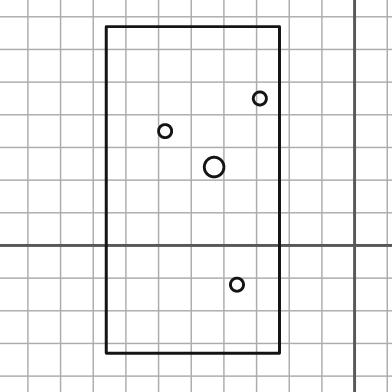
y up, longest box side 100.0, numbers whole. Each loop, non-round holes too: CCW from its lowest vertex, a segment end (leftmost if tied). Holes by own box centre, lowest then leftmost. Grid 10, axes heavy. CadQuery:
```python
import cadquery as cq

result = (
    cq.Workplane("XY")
    .moveTo(-76.0, -33.0)
    .lineTo(-23.0, -33.0)
    .lineTo(-23.0, 67.0)
    .lineTo(-76.0, 67.0)
    .close()
    .moveTo(-36.0, -12.0)
    .circle(2.0)
    .moveTo(-43.0, 24.0)
    .circle(3.0)
    .moveTo(-58.0, 35.0)
    .circle(2.0)
    .moveTo(-29.0, 45.0)
    .circle(2.0)
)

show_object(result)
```